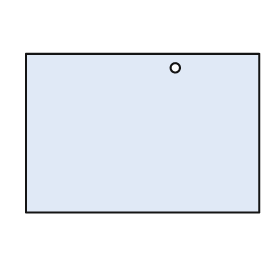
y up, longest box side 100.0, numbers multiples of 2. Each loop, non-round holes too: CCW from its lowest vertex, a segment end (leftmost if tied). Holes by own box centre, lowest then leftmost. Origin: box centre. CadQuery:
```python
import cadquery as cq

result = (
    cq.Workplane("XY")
    .moveTo(-50.0, -34.0)
    .lineTo(50.0, -34.0)
    .lineTo(50.0, 34.0)
    .lineTo(-50.0, 34.0)
    .close()
    .moveTo(14.0, 28.0)
    .circle(2.0)
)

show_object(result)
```